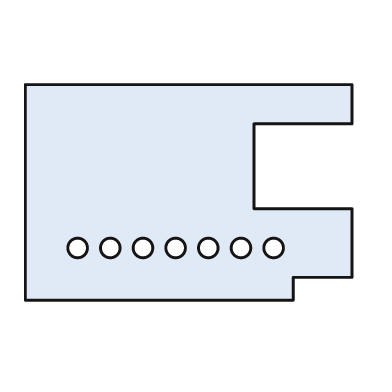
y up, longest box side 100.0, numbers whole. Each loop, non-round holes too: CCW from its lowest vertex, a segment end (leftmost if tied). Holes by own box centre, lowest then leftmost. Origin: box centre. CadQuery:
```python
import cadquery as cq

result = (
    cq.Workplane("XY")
    .moveTo(-50.0, -33.0)
    .lineTo(32.0, -33.0)
    .lineTo(32.0, -26.0)
    .lineTo(50.0, -26.0)
    .lineTo(50.0, -5.0)
    .lineTo(20.0, -5.0)
    .lineTo(20.0, 21.0)
    .lineTo(50.0, 21.0)
    .lineTo(50.0, 33.0)
    .lineTo(-50.0, 33.0)
    .close()
    .moveTo(-34.0, -17.0)
    .circle(3.0)
    .moveTo(-24.0, -17.0)
    .circle(3.0)
    .moveTo(-14.0, -17.0)
    .circle(3.0)
    .moveTo(-4.0, -17.0)
    .circle(3.0)
    .moveTo(6.0, -17.0)
    .circle(3.0)
    .moveTo(16.0, -17.0)
    .circle(3.0)
    .moveTo(26.0, -17.0)
    .circle(3.0)
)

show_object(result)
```